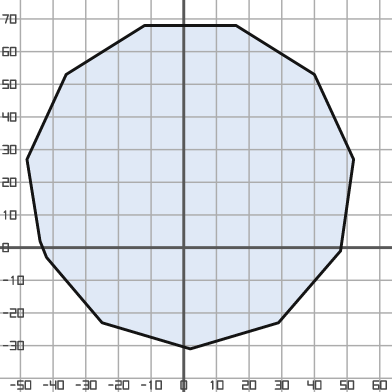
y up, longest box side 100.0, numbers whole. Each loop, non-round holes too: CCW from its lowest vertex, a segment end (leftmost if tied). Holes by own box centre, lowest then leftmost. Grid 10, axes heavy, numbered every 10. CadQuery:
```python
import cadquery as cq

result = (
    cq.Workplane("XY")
    .moveTo(2.0, -31.0)
    .lineTo(29.0, -23.0)
    .lineTo(48.0, -1.0)
    .lineTo(52.0, 27.0)
    .lineTo(40.0, 53.0)
    .lineTo(16.0, 68.0)
    .lineTo(-12.0, 68.0)
    .lineTo(-36.0, 53.0)
    .lineTo(-48.0, 27.0)
    .lineTo(-44.0, 2.0)
    .lineTo(-42.0, -3.0)
    .lineTo(-25.0, -23.0)
    .close()
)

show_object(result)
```